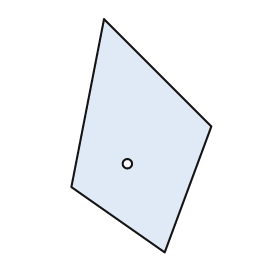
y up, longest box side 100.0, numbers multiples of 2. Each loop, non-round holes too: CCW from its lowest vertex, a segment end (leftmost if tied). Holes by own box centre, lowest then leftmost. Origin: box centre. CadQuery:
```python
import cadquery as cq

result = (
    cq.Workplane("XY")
    .moveTo(10.0, -50.0)
    .lineTo(30.0, 4.0)
    .lineTo(-16.0, 50.0)
    .lineTo(-30.0, -22.0)
    .close()
    .moveTo(-6.0, -12.0)
    .circle(2.0)
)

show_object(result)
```